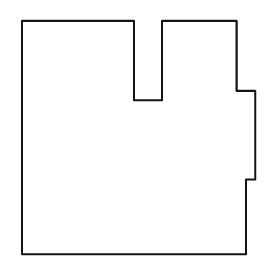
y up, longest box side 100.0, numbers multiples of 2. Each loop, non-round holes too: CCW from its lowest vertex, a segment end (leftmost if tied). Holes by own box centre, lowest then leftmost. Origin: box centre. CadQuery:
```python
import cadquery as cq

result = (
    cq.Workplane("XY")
    .moveTo(-50.0, -50.0)
    .lineTo(46.0, -50.0)
    .lineTo(46.0, -18.0)
    .lineTo(50.0, -18.0)
    .lineTo(50.0, 20.0)
    .lineTo(42.0, 20.0)
    .lineTo(42.0, 50.0)
    .lineTo(10.0, 50.0)
    .lineTo(10.0, 16.0)
    .lineTo(-2.0, 16.0)
    .lineTo(-2.0, 50.0)
    .lineTo(-50.0, 50.0)
    .close()
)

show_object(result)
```